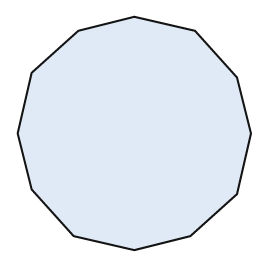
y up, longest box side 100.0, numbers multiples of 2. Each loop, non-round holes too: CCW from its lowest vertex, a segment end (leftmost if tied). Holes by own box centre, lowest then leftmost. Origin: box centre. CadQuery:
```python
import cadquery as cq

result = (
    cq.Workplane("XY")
    .moveTo(0.0, -50.0)
    .lineTo(24.0, -44.0)
    .lineTo(44.0, -26.0)
    .lineTo(50.0, 0.0)
    .lineTo(44.0, 24.0)
    .lineTo(26.0, 44.0)
    .lineTo(0.0, 50.0)
    .lineTo(-24.0, 44.0)
    .lineTo(-44.0, 26.0)
    .lineTo(-50.0, 0.0)
    .lineTo(-44.0, -24.0)
    .lineTo(-26.0, -44.0)
    .close()
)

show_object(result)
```